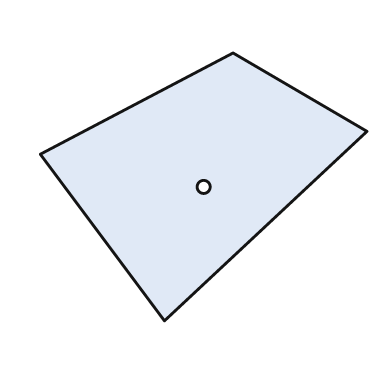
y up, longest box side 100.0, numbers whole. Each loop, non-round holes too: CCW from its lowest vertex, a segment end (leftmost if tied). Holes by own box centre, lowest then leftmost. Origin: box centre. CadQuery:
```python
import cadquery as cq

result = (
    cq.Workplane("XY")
    .moveTo(-12.0, -41.0)
    .lineTo(50.0, 17.0)
    .lineTo(9.0, 41.0)
    .lineTo(-50.0, 10.0)
    .close()
    .moveTo(0.0, 0.0)
    .circle(2.0)
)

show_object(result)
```